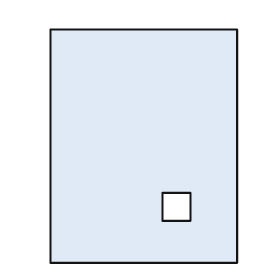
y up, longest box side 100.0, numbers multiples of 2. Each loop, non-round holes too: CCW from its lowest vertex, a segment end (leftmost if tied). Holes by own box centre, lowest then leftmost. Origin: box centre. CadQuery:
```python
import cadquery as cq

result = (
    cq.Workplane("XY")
    .moveTo(-40.0, -50.0)
    .lineTo(40.0, -50.0)
    .lineTo(40.0, 50.0)
    .lineTo(-40.0, 50.0)
    .close()
    .moveTo(8.0, -32.0)
    .lineTo(20.0, -32.0)
    .lineTo(20.0, -20.0)
    .lineTo(8.0, -20.0)
    .close()
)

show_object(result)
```